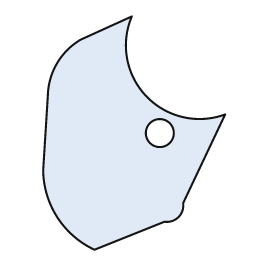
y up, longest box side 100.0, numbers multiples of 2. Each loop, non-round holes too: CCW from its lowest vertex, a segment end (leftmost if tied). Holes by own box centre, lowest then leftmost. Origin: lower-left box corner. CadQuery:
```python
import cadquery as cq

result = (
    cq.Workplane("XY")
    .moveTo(22.0, 0.0)
    .lineTo(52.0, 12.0)
    .threePointArc((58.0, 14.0), (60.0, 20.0))
    .lineTo(78.0, 58.0)
    .threePointArc((44.0, 66.0), (38.0, 100.0))
    .lineTo(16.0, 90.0)
    .threePointArc((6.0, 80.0), (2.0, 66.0))
    .lineTo(0.0, 34.0)
    .threePointArc((6.0, 14.0), (22.0, 0.0))
    .close()
    .moveTo(50.0, 50.0)
    .circle(6.0)
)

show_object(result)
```